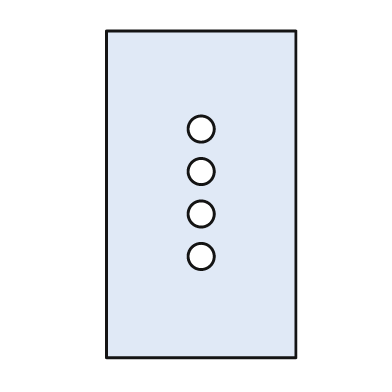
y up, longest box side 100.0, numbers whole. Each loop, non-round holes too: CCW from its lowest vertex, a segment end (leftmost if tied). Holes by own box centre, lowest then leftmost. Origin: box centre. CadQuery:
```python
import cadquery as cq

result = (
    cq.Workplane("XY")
    .moveTo(-29.0, -50.0)
    .lineTo(29.0, -50.0)
    .lineTo(29.0, 50.0)
    .lineTo(-29.0, 50.0)
    .close()
    .moveTo(0.0, -19.0)
    .circle(4.0)
    .moveTo(0.0, -6.0)
    .circle(4.0)
    .moveTo(0.0, 7.0)
    .circle(4.0)
    .moveTo(0.0, 20.0)
    .circle(4.0)
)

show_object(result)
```